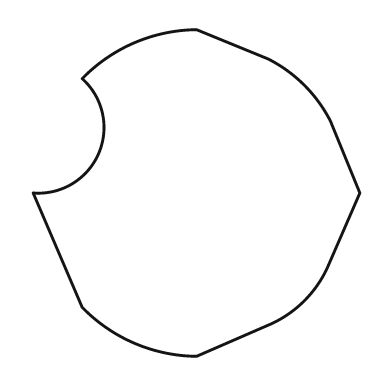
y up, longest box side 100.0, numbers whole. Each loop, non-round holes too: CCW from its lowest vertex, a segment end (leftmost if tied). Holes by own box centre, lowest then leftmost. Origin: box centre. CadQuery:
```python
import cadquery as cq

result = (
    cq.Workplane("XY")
    .moveTo(0.0, -50.0)
    .lineTo(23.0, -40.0)
    .threePointArc((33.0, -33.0), (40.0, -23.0))
    .lineTo(50.0, 0.0)
    .lineTo(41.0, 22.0)
    .threePointArc((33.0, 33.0), (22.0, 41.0))
    .lineTo(0.0, 50.0)
    .threePointArc((-19.0, 46.0), (-35.0, 35.0))
    .threePointArc((-30.0, 12.0), (-50.0, 0.0))
    .lineTo(-35.0, -35.0)
    .threePointArc((-19.0, -46.0), (0.0, -50.0))
    .close()
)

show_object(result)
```